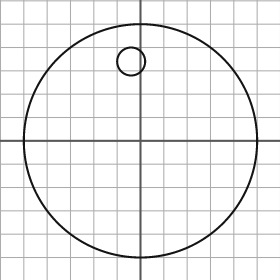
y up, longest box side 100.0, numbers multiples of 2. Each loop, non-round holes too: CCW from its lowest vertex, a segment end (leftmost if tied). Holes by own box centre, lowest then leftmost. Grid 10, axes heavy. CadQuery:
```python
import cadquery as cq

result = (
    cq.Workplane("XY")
    .moveTo(0.0, 0.0)
    .circle(50.0)
    .moveTo(-4.0, 34.0)
    .circle(6.0)
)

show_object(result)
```